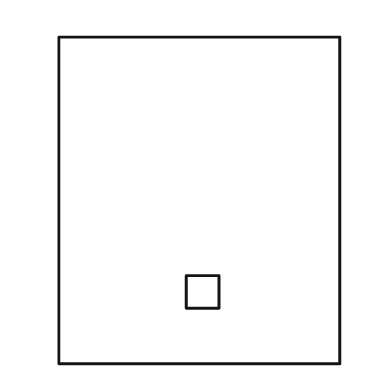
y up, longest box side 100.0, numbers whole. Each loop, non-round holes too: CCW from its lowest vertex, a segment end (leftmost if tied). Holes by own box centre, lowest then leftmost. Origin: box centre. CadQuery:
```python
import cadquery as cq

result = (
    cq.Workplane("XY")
    .moveTo(-43.0, -50.0)
    .lineTo(43.0, -50.0)
    .lineTo(43.0, 50.0)
    .lineTo(-43.0, 50.0)
    .close()
    .moveTo(-4.0, -33.0)
    .lineTo(6.0, -33.0)
    .lineTo(6.0, -23.0)
    .lineTo(-4.0, -23.0)
    .close()
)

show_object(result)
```